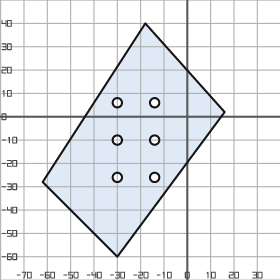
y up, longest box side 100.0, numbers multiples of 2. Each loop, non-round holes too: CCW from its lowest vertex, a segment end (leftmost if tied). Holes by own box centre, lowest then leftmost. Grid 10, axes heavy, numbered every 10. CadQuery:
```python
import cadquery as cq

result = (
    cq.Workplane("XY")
    .moveTo(-30.0, -60.0)
    .lineTo(16.0, 2.0)
    .lineTo(-18.0, 40.0)
    .lineTo(-62.0, -28.0)
    .close()
    .moveTo(-30.0, -26.0)
    .circle(2.0)
    .moveTo(-14.0, -26.0)
    .circle(2.0)
    .moveTo(-30.0, -10.0)
    .circle(2.0)
    .moveTo(-14.0, -10.0)
    .circle(2.0)
    .moveTo(-30.0, 6.0)
    .circle(2.0)
    .moveTo(-14.0, 6.0)
    .circle(2.0)
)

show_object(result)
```